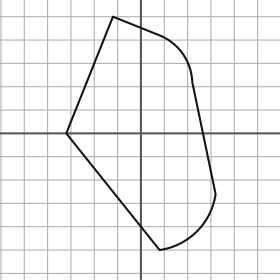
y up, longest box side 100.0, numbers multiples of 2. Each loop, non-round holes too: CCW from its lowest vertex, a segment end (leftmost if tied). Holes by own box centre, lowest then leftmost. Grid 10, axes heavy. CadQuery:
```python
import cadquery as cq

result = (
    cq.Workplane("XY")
    .moveTo(8.0, -50.0)
    .threePointArc((24.0, -42.0), (32.0, -26.0))
    .lineTo(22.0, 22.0)
    .threePointArc((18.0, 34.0), (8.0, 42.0))
    .lineTo(-12.0, 50.0)
    .lineTo(-32.0, 0.0)
    .close()
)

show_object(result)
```